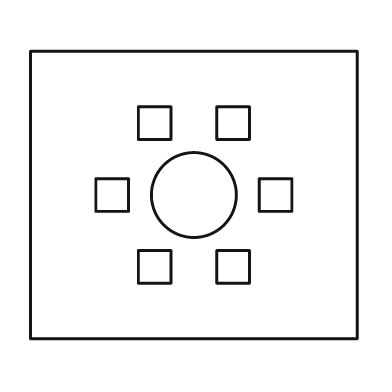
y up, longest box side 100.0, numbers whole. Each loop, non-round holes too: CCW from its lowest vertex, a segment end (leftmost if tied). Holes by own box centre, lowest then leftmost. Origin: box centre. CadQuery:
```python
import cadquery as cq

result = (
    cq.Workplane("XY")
    .moveTo(-50.0, -44.0)
    .lineTo(50.0, -44.0)
    .lineTo(50.0, 44.0)
    .lineTo(-50.0, 44.0)
    .close()
    .moveTo(-17.0, -27.0)
    .lineTo(-7.0, -27.0)
    .lineTo(-7.0, -17.0)
    .lineTo(-17.0, -17.0)
    .close()
    .moveTo(7.0, -27.0)
    .lineTo(17.0, -27.0)
    .lineTo(17.0, -17.0)
    .lineTo(7.0, -17.0)
    .close()
    .moveTo(-30.0, -5.0)
    .lineTo(-20.0, -5.0)
    .lineTo(-20.0, 5.0)
    .lineTo(-30.0, 5.0)
    .close()
    .moveTo(0.0, 0.0)
    .circle(13.0)
    .moveTo(20.0, -5.0)
    .lineTo(30.0, -5.0)
    .lineTo(30.0, 5.0)
    .lineTo(20.0, 5.0)
    .close()
    .moveTo(-17.0, 17.0)
    .lineTo(-7.0, 17.0)
    .lineTo(-7.0, 27.0)
    .lineTo(-17.0, 27.0)
    .close()
    .moveTo(7.0, 17.0)
    .lineTo(17.0, 17.0)
    .lineTo(17.0, 27.0)
    .lineTo(7.0, 27.0)
    .close()
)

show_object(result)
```